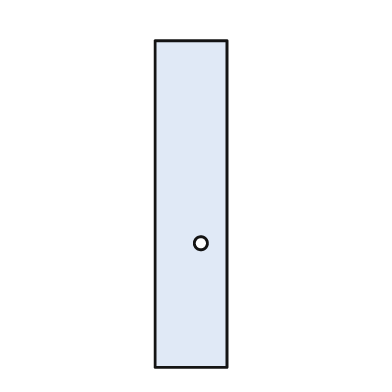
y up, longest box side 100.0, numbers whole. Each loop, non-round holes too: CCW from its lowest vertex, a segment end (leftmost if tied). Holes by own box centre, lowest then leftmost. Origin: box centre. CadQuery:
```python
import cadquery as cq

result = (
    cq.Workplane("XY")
    .moveTo(-11.0, -50.0)
    .lineTo(11.0, -50.0)
    .lineTo(11.0, 50.0)
    .lineTo(-11.0, 50.0)
    .close()
    .moveTo(3.0, -12.0)
    .circle(2.0)
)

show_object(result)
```